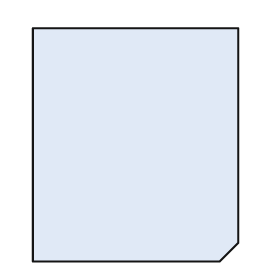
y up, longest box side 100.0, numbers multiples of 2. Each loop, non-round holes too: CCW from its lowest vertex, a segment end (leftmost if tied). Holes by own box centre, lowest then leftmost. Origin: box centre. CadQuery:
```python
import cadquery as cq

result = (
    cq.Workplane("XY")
    .moveTo(-44.0, -50.0)
    .lineTo(36.0, -50.0)
    .lineTo(44.0, -42.0)
    .lineTo(44.0, 50.0)
    .lineTo(-44.0, 50.0)
    .close()
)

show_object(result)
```